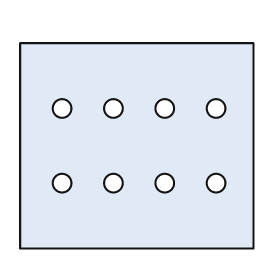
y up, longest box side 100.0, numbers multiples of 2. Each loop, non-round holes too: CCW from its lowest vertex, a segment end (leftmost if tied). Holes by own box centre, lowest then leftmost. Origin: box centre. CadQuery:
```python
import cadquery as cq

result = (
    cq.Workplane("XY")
    .moveTo(-50.0, -44.0)
    .lineTo(50.0, -44.0)
    .lineTo(50.0, 44.0)
    .lineTo(-50.0, 44.0)
    .close()
    .moveTo(-32.0, -16.0)
    .circle(4.0)
    .moveTo(-10.0, -16.0)
    .circle(4.0)
    .moveTo(12.0, -16.0)
    .circle(4.0)
    .moveTo(34.0, -16.0)
    .circle(4.0)
    .moveTo(-32.0, 16.0)
    .circle(4.0)
    .moveTo(-10.0, 16.0)
    .circle(4.0)
    .moveTo(12.0, 16.0)
    .circle(4.0)
    .moveTo(34.0, 16.0)
    .circle(4.0)
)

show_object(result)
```